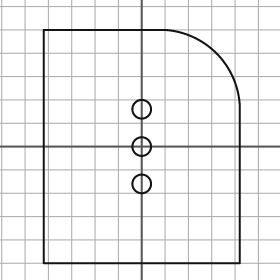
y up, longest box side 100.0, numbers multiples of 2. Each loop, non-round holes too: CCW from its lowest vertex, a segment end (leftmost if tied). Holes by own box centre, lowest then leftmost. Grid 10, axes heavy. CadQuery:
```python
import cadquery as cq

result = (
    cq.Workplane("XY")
    .moveTo(-42.0, -50.0)
    .lineTo(42.0, -50.0)
    .lineTo(42.0, 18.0)
    .threePointArc((32.0, 40.0), (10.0, 50.0))
    .lineTo(-42.0, 50.0)
    .close()
    .moveTo(0.0, -16.0)
    .circle(4.0)
    .moveTo(0.0, 0.0)
    .circle(4.0)
    .moveTo(0.0, 16.0)
    .circle(4.0)
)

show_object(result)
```